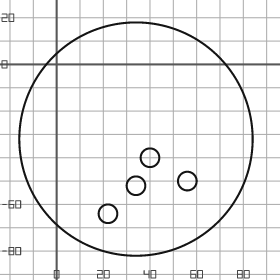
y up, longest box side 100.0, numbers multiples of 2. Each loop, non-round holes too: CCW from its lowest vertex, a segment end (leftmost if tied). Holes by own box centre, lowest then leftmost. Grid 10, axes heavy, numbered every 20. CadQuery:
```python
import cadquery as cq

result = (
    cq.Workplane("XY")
    .moveTo(34.0, -32.0)
    .circle(50.0)
    .moveTo(22.0, -64.0)
    .circle(4.0)
    .moveTo(34.0, -52.0)
    .circle(4.0)
    .moveTo(56.0, -50.0)
    .circle(4.0)
    .moveTo(40.0, -40.0)
    .circle(4.0)
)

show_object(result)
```